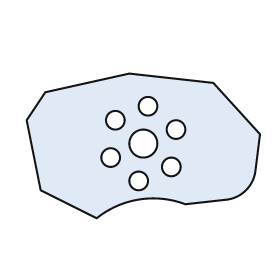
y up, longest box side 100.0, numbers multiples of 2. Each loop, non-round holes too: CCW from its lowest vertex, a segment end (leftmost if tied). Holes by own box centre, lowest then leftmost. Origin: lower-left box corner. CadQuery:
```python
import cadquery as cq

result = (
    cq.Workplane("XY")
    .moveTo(30.0, 0.0)
    .threePointArc((48.0, 8.0), (68.0, 6.0))
    .lineTo(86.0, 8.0)
    .threePointArc((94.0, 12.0), (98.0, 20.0))
    .lineTo(100.0, 36.0)
    .lineTo(80.0, 58.0)
    .lineTo(44.0, 62.0)
    .lineTo(8.0, 54.0)
    .lineTo(0.0, 42.0)
    .lineTo(6.0, 12.0)
    .close()
    .moveTo(48.0, 16.0)
    .circle(4.0)
    .moveTo(62.0, 22.0)
    .circle(4.0)
    .moveTo(36.0, 26.0)
    .circle(4.0)
    .moveTo(50.0, 32.0)
    .circle(6.0)
    .moveTo(64.0, 38.0)
    .circle(4.0)
    .moveTo(38.0, 42.0)
    .circle(4.0)
    .moveTo(52.0, 48.0)
    .circle(4.0)
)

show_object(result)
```